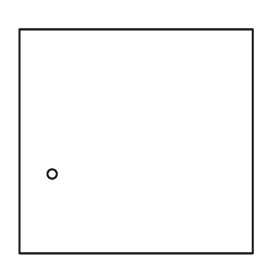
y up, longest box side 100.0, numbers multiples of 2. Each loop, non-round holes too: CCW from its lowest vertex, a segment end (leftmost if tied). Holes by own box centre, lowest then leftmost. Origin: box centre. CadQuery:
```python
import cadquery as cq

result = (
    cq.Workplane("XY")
    .moveTo(-50.0, -48.0)
    .lineTo(50.0, -48.0)
    .lineTo(50.0, 48.0)
    .lineTo(-50.0, 48.0)
    .close()
    .moveTo(-36.0, -14.0)
    .circle(2.0)
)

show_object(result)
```